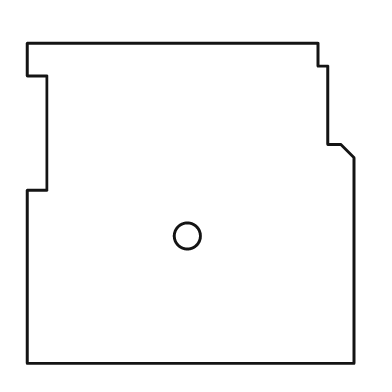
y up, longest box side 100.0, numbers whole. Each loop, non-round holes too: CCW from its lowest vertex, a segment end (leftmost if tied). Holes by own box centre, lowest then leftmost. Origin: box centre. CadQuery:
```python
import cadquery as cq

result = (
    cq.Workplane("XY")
    .moveTo(-50.0, -49.0)
    .lineTo(50.0, -49.0)
    .lineTo(50.0, 14.0)
    .lineTo(46.0, 18.0)
    .lineTo(42.0, 18.0)
    .lineTo(42.0, 42.0)
    .lineTo(39.0, 42.0)
    .lineTo(39.0, 49.0)
    .lineTo(-50.0, 49.0)
    .lineTo(-50.0, 39.0)
    .lineTo(-44.0, 39.0)
    .lineTo(-44.0, 4.0)
    .lineTo(-50.0, 4.0)
    .close()
    .moveTo(-1.0, -10.0)
    .circle(4.0)
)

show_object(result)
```